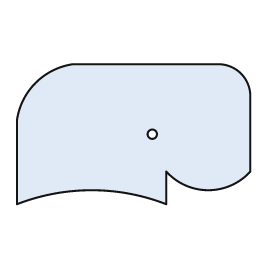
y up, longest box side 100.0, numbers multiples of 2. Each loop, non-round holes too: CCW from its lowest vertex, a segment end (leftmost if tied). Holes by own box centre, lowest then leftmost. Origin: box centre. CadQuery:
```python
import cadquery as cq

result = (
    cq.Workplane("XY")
    .moveTo(-50.0, -30.0)
    .threePointArc((-18.0, -24.0), (14.0, -30.0))
    .lineTo(14.0, -16.0)
    .threePointArc((32.0, -24.0), (50.0, -16.0))
    .lineTo(50.0, 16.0)
    .threePointArc((46.0, 26.0), (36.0, 30.0))
    .lineTo(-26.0, 30.0)
    .threePointArc((-42.0, 22.0), (-50.0, 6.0))
    .close()
    .moveTo(8.0, 0.0)
    .circle(2.0)
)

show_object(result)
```